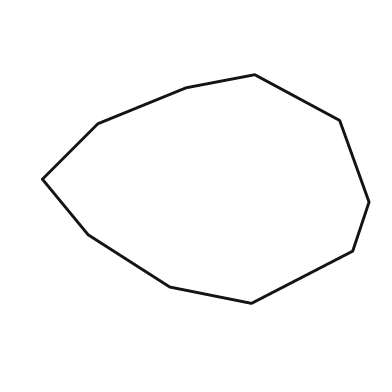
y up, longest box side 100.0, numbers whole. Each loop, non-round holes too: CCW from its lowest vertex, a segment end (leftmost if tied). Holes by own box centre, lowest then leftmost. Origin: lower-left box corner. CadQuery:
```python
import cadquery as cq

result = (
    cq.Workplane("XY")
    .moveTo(64.0, 0.0)
    .lineTo(95.0, 16.0)
    .lineTo(100.0, 31.0)
    .lineTo(91.0, 56.0)
    .lineTo(65.0, 70.0)
    .lineTo(44.0, 66.0)
    .lineTo(17.0, 55.0)
    .lineTo(0.0, 38.0)
    .lineTo(14.0, 21.0)
    .lineTo(39.0, 5.0)
    .close()
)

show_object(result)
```